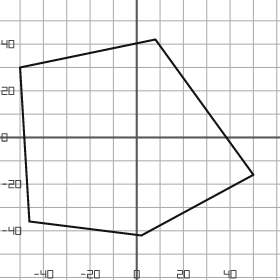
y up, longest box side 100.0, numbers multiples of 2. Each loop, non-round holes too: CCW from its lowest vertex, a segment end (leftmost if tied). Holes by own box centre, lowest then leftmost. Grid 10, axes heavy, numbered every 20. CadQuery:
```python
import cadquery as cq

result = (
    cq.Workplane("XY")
    .moveTo(2.0, -42.0)
    .lineTo(50.0, -16.0)
    .lineTo(8.0, 42.0)
    .lineTo(-50.0, 30.0)
    .lineTo(-46.0, -36.0)
    .close()
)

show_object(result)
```